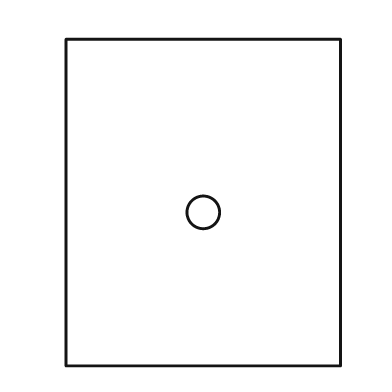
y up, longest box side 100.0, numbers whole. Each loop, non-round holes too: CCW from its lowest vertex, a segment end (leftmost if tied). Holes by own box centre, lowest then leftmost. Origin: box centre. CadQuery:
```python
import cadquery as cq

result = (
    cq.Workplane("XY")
    .moveTo(-42.0, -50.0)
    .lineTo(42.0, -50.0)
    .lineTo(42.0, 50.0)
    .lineTo(-42.0, 50.0)
    .close()
    .moveTo(0.0, -3.0)
    .circle(5.0)
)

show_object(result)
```